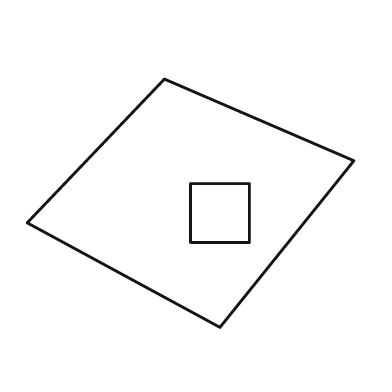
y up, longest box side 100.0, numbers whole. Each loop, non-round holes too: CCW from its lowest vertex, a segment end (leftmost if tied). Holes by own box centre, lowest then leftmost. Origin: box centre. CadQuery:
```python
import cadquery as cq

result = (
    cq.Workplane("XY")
    .moveTo(9.0, -38.0)
    .lineTo(50.0, 13.0)
    .lineTo(-8.0, 38.0)
    .lineTo(-50.0, -6.0)
    .close()
    .moveTo(0.0, -12.0)
    .lineTo(18.0, -12.0)
    .lineTo(18.0, 6.0)
    .lineTo(0.0, 6.0)
    .close()
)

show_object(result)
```